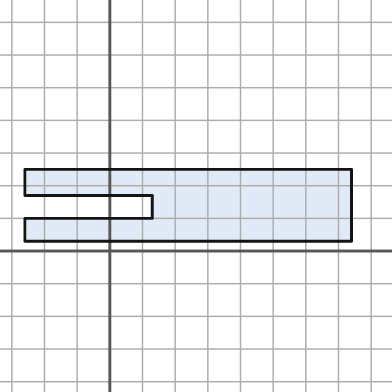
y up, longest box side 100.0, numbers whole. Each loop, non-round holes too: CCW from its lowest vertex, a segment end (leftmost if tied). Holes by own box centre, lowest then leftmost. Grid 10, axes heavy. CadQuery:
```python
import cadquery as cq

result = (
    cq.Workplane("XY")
    .moveTo(-26.0, 3.0)
    .lineTo(74.0, 3.0)
    .lineTo(74.0, 25.0)
    .lineTo(-26.0, 25.0)
    .lineTo(-26.0, 17.0)
    .lineTo(13.0, 17.0)
    .lineTo(13.0, 10.0)
    .lineTo(-26.0, 10.0)
    .close()
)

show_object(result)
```